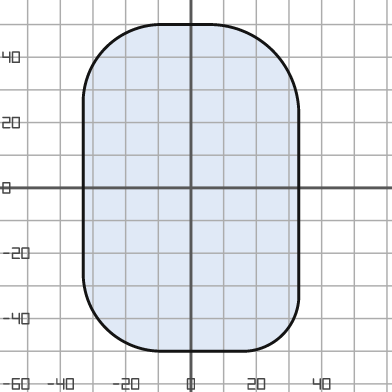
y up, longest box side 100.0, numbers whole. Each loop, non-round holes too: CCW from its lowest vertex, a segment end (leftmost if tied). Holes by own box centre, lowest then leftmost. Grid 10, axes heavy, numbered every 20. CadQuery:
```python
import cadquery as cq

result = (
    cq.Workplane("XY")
    .moveTo(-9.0, -50.0)
    .lineTo(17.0, -50.0)
    .threePointArc((28.0, -45.0), (33.0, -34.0))
    .lineTo(33.0, 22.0)
    .threePointArc((25.0, 42.0), (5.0, 50.0))
    .lineTo(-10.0, 50.0)
    .threePointArc((-26.0, 43.0), (-33.0, 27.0))
    .lineTo(-33.0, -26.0)
    .threePointArc((-26.0, -43.0), (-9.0, -50.0))
    .close()
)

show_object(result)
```